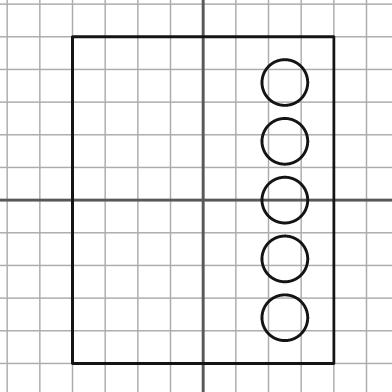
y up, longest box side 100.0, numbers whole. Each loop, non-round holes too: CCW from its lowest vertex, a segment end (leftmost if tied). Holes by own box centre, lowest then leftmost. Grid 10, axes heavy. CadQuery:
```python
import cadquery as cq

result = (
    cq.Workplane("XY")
    .moveTo(-40.0, -50.0)
    .lineTo(40.0, -50.0)
    .lineTo(40.0, 50.0)
    .lineTo(-40.0, 50.0)
    .close()
    .moveTo(25.0, -36.0)
    .circle(7.0)
    .moveTo(25.0, -18.0)
    .circle(7.0)
    .moveTo(25.0, 0.0)
    .circle(7.0)
    .moveTo(25.0, 18.0)
    .circle(7.0)
    .moveTo(25.0, 36.0)
    .circle(7.0)
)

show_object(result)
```